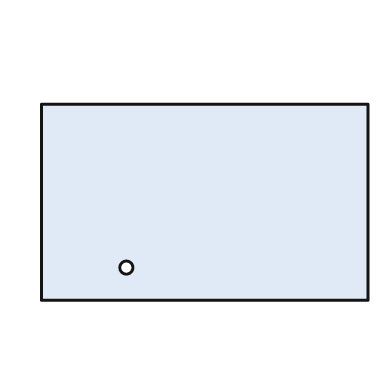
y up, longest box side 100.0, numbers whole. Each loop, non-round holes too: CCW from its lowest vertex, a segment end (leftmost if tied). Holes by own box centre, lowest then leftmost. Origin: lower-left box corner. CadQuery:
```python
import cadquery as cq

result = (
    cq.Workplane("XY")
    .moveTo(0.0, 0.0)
    .lineTo(100.0, 0.0)
    .lineTo(100.0, 60.0)
    .lineTo(0.0, 60.0)
    .close()
    .moveTo(26.0, 10.0)
    .circle(2.0)
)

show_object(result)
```